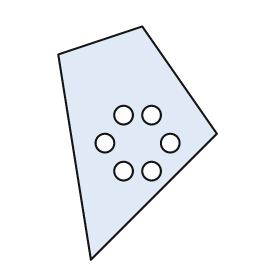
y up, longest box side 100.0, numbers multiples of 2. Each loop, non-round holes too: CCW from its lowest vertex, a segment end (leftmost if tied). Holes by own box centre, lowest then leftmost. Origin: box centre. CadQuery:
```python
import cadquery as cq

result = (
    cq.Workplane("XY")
    .moveTo(-20.0, -50.0)
    .lineTo(34.0, 4.0)
    .lineTo(2.0, 50.0)
    .lineTo(-34.0, 38.0)
    .close()
    .moveTo(-6.0, -12.0)
    .circle(4.0)
    .moveTo(6.0, -12.0)
    .circle(4.0)
    .moveTo(-14.0, 0.0)
    .circle(4.0)
    .moveTo(14.0, 0.0)
    .circle(4.0)
    .moveTo(-6.0, 12.0)
    .circle(4.0)
    .moveTo(6.0, 12.0)
    .circle(4.0)
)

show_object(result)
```